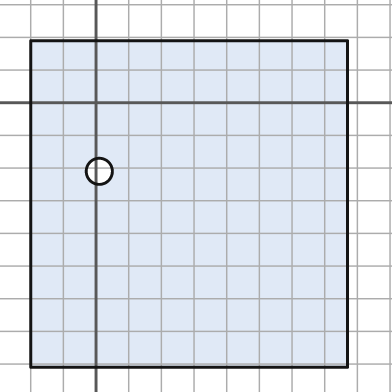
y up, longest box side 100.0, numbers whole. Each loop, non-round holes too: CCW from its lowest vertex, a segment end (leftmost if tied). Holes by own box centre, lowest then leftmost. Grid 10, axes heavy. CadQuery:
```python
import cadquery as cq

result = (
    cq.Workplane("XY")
    .moveTo(-20.0, -81.0)
    .lineTo(77.0, -81.0)
    .lineTo(77.0, 19.0)
    .lineTo(-20.0, 19.0)
    .close()
    .moveTo(1.0, -21.0)
    .circle(4.0)
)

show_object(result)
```